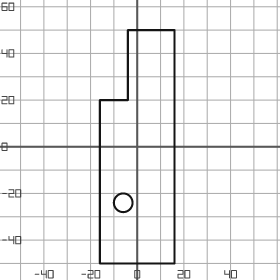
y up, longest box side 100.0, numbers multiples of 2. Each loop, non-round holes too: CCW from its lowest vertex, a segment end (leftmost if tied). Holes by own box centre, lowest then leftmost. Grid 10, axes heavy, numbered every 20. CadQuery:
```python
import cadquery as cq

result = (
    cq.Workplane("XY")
    .moveTo(-16.0, -50.0)
    .lineTo(16.0, -50.0)
    .lineTo(16.0, 50.0)
    .lineTo(-4.0, 50.0)
    .lineTo(-4.0, 20.0)
    .lineTo(-16.0, 20.0)
    .close()
    .moveTo(-6.0, -24.0)
    .circle(4.0)
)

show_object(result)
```